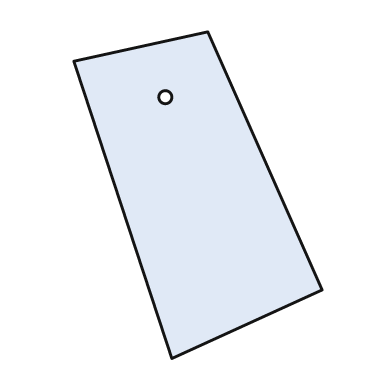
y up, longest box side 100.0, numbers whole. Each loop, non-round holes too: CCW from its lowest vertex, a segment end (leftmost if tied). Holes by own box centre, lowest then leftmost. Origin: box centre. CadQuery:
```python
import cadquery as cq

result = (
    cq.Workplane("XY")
    .moveTo(-8.0, -50.0)
    .lineTo(38.0, -29.0)
    .lineTo(3.0, 50.0)
    .lineTo(-38.0, 41.0)
    .close()
    .moveTo(-10.0, 30.0)
    .circle(2.0)
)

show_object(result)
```